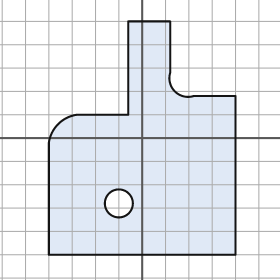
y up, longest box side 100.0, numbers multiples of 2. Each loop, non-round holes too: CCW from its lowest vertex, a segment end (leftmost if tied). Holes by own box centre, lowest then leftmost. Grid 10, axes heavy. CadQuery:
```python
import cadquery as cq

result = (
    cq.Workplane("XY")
    .moveTo(-40.0, -50.0)
    .lineTo(40.0, -50.0)
    .lineTo(40.0, 18.0)
    .lineTo(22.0, 18.0)
    .threePointArc((14.0, 20.0), (12.0, 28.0))
    .lineTo(12.0, 50.0)
    .lineTo(-6.0, 50.0)
    .lineTo(-6.0, 10.0)
    .lineTo(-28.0, 10.0)
    .threePointArc((-36.0, 6.0), (-40.0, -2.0))
    .close()
    .moveTo(-10.0, -28.0)
    .circle(6.0)
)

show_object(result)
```